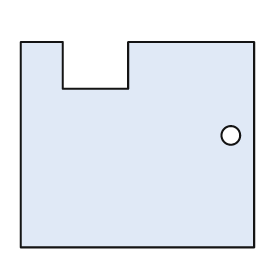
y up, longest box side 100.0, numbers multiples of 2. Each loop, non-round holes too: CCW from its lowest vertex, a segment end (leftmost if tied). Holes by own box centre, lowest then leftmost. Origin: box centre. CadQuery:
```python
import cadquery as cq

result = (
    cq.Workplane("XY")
    .moveTo(-50.0, -44.0)
    .lineTo(50.0, -44.0)
    .lineTo(50.0, 44.0)
    .lineTo(-4.0, 44.0)
    .lineTo(-4.0, 24.0)
    .lineTo(-32.0, 24.0)
    .lineTo(-32.0, 44.0)
    .lineTo(-50.0, 44.0)
    .close()
    .moveTo(40.0, 4.0)
    .circle(4.0)
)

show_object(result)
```